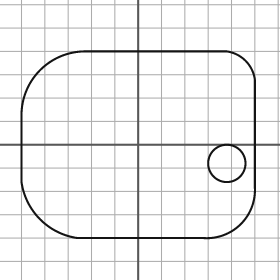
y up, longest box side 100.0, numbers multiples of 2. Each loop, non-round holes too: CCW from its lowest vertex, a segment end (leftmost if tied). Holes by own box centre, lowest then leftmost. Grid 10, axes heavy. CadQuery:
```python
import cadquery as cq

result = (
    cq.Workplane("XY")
    .moveTo(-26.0, -40.0)
    .lineTo(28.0, -40.0)
    .threePointArc((44.0, -34.0), (50.0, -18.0))
    .lineTo(50.0, 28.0)
    .threePointArc((46.0, 36.0), (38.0, 40.0))
    .lineTo(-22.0, 40.0)
    .threePointArc((-42.0, 32.0), (-50.0, 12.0))
    .lineTo(-50.0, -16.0)
    .threePointArc((-42.0, -32.0), (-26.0, -40.0))
    .close()
    .moveTo(38.0, -8.0)
    .circle(8.0)
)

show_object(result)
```